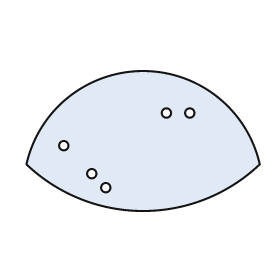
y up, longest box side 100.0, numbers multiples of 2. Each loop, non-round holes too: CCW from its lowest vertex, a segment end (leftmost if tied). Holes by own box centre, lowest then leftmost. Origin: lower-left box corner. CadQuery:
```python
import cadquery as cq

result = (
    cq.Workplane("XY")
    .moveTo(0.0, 20.0)
    .threePointArc((50.0, 0.0), (100.0, 20.0))
    .threePointArc((50.0, 60.0), (0.0, 20.0))
    .close()
    .moveTo(34.0, 10.0)
    .circle(2.0)
    .moveTo(28.0, 16.0)
    .circle(2.0)
    .moveTo(16.0, 28.0)
    .circle(2.0)
    .moveTo(60.0, 42.0)
    .circle(2.0)
    .moveTo(70.0, 42.0)
    .circle(2.0)
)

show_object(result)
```